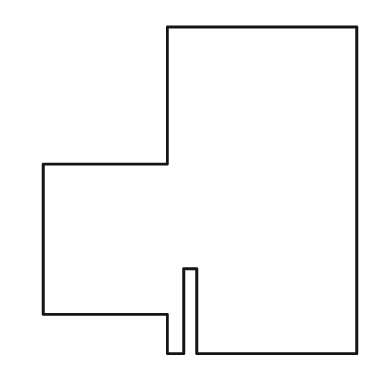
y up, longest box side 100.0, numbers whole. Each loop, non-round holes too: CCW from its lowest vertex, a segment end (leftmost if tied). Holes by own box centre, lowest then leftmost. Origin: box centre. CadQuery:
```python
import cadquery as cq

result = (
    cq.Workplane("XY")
    .moveTo(-10.0, -50.0)
    .lineTo(-5.0, -50.0)
    .lineTo(-5.0, -24.0)
    .lineTo(-1.0, -24.0)
    .lineTo(-1.0, -50.0)
    .lineTo(48.0, -50.0)
    .lineTo(48.0, 50.0)
    .lineTo(-10.0, 50.0)
    .lineTo(-10.0, 8.0)
    .lineTo(-48.0, 8.0)
    .lineTo(-48.0, -38.0)
    .lineTo(-10.0, -38.0)
    .close()
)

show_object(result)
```